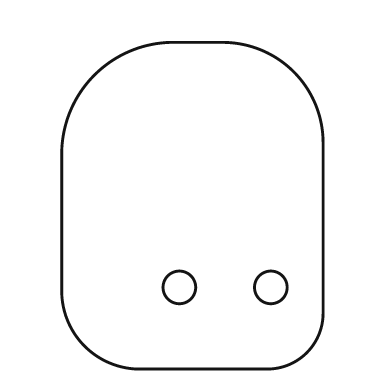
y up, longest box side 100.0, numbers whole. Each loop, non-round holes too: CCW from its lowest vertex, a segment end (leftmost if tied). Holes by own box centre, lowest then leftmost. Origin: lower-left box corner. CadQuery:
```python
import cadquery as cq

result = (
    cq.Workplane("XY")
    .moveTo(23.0, 0.0)
    .lineTo(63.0, 0.0)
    .threePointArc((75.0, 5.0), (80.0, 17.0))
    .lineTo(80.0, 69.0)
    .threePointArc((71.0, 91.0), (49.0, 100.0))
    .lineTo(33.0, 100.0)
    .threePointArc((10.0, 90.0), (0.0, 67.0))
    .lineTo(0.0, 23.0)
    .threePointArc((7.0, 7.0), (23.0, 0.0))
    .close()
    .moveTo(36.0, 25.0)
    .circle(5.0)
    .moveTo(64.0, 25.0)
    .circle(5.0)
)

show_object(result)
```